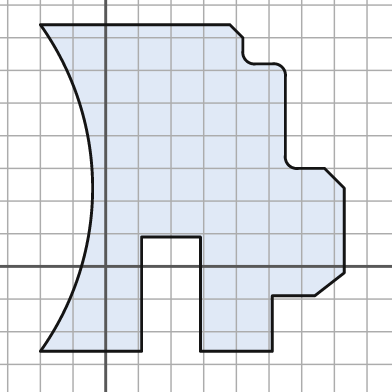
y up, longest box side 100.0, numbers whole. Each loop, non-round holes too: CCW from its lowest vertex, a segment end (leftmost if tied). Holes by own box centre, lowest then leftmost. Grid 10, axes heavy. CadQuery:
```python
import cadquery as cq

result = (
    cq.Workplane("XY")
    .moveTo(-20.0, -26.0)
    .lineTo(11.0, -26.0)
    .lineTo(11.0, 9.0)
    .lineTo(29.0, 9.0)
    .lineTo(29.0, -26.0)
    .lineTo(51.0, -26.0)
    .lineTo(51.0, -9.0)
    .lineTo(64.0, -9.0)
    .lineTo(73.0, -2.0)
    .lineTo(73.0, 24.0)
    .lineTo(67.0, 30.0)
    .lineTo(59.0, 30.0)
    .threePointArc((56.0, 31.0), (55.0, 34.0))
    .lineTo(55.0, 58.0)
    .threePointArc((54.0, 61.0), (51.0, 62.0))
    .lineTo(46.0, 62.0)
    .threePointArc((43.0, 63.0), (42.0, 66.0))
    .lineTo(42.0, 70.0)
    .lineTo(38.0, 74.0)
    .lineTo(-20.0, 74.0)
    .threePointArc((-4.0, 24.0), (-20.0, -26.0))
    .close()
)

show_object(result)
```